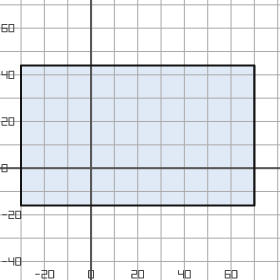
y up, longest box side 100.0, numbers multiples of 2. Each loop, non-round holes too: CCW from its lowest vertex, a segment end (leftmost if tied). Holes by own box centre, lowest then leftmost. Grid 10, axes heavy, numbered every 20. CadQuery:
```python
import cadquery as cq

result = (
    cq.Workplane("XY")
    .moveTo(-30.0, -16.0)
    .lineTo(70.0, -16.0)
    .lineTo(70.0, 44.0)
    .lineTo(-30.0, 44.0)
    .close()
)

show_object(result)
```